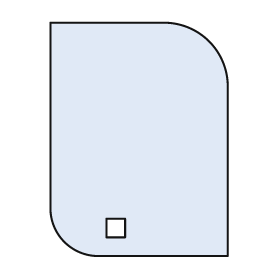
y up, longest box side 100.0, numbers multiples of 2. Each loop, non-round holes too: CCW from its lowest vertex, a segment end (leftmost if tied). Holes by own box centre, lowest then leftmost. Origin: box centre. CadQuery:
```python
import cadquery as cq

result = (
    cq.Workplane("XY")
    .moveTo(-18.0, -50.0)
    .lineTo(38.0, -50.0)
    .lineTo(38.0, 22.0)
    .threePointArc((30.0, 42.0), (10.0, 50.0))
    .lineTo(-38.0, 50.0)
    .lineTo(-38.0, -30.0)
    .threePointArc((-32.0, -44.0), (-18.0, -50.0))
    .close()
    .moveTo(-14.0, -42.0)
    .lineTo(-6.0, -42.0)
    .lineTo(-6.0, -34.0)
    .lineTo(-14.0, -34.0)
    .close()
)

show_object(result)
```